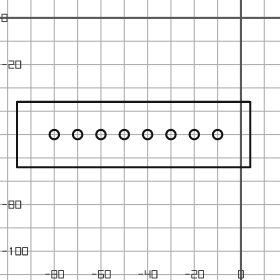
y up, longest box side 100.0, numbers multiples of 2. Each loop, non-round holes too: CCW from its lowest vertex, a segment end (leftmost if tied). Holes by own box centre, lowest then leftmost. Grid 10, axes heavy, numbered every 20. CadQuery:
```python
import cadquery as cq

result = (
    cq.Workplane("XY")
    .moveTo(-96.0, -64.0)
    .lineTo(4.0, -64.0)
    .lineTo(4.0, -36.0)
    .lineTo(-96.0, -36.0)
    .close()
    .moveTo(-80.0, -50.0)
    .circle(2.0)
    .moveTo(-70.0, -50.0)
    .circle(2.0)
    .moveTo(-60.0, -50.0)
    .circle(2.0)
    .moveTo(-50.0, -50.0)
    .circle(2.0)
    .moveTo(-40.0, -50.0)
    .circle(2.0)
    .moveTo(-30.0, -50.0)
    .circle(2.0)
    .moveTo(-20.0, -50.0)
    .circle(2.0)
    .moveTo(-10.0, -50.0)
    .circle(2.0)
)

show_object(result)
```